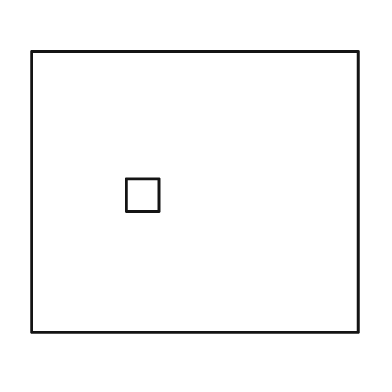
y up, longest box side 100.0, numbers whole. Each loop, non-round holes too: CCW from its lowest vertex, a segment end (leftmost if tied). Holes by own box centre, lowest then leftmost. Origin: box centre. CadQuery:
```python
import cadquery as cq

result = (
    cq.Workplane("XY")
    .moveTo(-50.0, -43.0)
    .lineTo(50.0, -43.0)
    .lineTo(50.0, 43.0)
    .lineTo(-50.0, 43.0)
    .close()
    .moveTo(-21.0, -6.0)
    .lineTo(-11.0, -6.0)
    .lineTo(-11.0, 4.0)
    .lineTo(-21.0, 4.0)
    .close()
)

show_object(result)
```